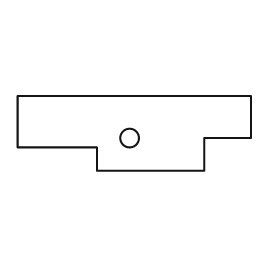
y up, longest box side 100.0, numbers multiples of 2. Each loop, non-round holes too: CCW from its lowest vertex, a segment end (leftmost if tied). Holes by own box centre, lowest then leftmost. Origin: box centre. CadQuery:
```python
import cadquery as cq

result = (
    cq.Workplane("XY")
    .moveTo(-16.0, -16.0)
    .lineTo(30.0, -16.0)
    .lineTo(30.0, -2.0)
    .lineTo(50.0, -2.0)
    .lineTo(50.0, 16.0)
    .lineTo(-50.0, 16.0)
    .lineTo(-50.0, -6.0)
    .lineTo(-16.0, -6.0)
    .close()
    .moveTo(-2.0, -2.0)
    .circle(4.0)
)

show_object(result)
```